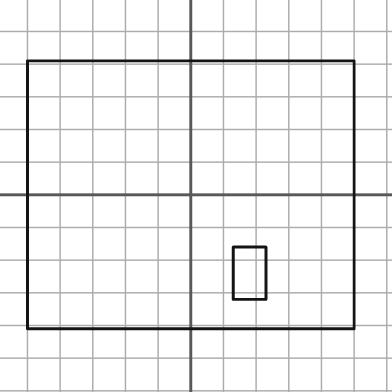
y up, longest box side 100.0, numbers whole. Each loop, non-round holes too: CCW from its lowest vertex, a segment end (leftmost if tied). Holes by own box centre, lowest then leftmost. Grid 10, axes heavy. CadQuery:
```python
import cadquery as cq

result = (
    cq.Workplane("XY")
    .moveTo(-50.0, -41.0)
    .lineTo(50.0, -41.0)
    .lineTo(50.0, 41.0)
    .lineTo(-50.0, 41.0)
    .close()
    .moveTo(13.0, -32.0)
    .lineTo(23.0, -32.0)
    .lineTo(23.0, -16.0)
    .lineTo(13.0, -16.0)
    .close()
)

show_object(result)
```